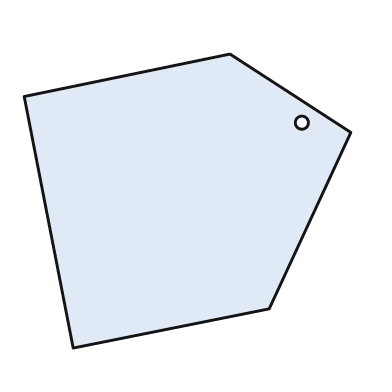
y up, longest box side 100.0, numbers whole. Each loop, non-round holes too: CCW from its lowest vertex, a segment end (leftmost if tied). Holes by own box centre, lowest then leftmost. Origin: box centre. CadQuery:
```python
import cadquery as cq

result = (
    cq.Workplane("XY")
    .moveTo(-35.0, -45.0)
    .lineTo(25.0, -33.0)
    .lineTo(50.0, 21.0)
    .lineTo(13.0, 45.0)
    .lineTo(-50.0, 32.0)
    .close()
    .moveTo(35.0, 24.0)
    .circle(2.0)
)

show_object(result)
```